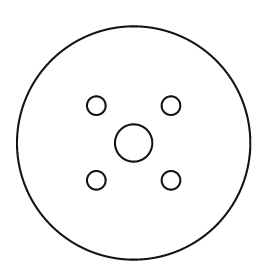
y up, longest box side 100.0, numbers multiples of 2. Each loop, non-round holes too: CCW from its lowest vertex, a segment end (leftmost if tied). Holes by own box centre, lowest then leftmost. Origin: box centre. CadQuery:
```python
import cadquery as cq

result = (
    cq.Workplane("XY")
    .moveTo(0.0, 0.0)
    .circle(50.0)
    .moveTo(-16.0, -16.0)
    .circle(4.0)
    .moveTo(16.0, -16.0)
    .circle(4.0)
    .moveTo(0.0, 0.0)
    .circle(8.0)
    .moveTo(-16.0, 16.0)
    .circle(4.0)
    .moveTo(16.0, 16.0)
    .circle(4.0)
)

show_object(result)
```